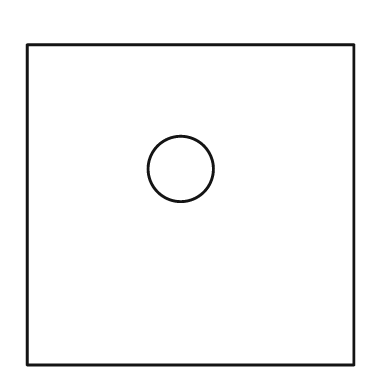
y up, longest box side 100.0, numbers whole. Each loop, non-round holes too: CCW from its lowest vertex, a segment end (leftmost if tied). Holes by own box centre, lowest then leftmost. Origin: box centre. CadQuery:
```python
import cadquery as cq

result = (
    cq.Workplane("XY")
    .moveTo(-50.0, -49.0)
    .lineTo(50.0, -49.0)
    .lineTo(50.0, 49.0)
    .lineTo(-50.0, 49.0)
    .close()
    .moveTo(-3.0, 11.0)
    .circle(10.0)
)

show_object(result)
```